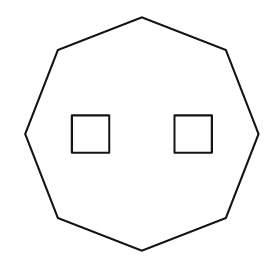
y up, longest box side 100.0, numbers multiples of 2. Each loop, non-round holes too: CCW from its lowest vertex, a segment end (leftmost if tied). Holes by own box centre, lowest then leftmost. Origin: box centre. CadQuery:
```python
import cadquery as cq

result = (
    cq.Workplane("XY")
    .moveTo(0.0, -50.0)
    .lineTo(36.0, -36.0)
    .lineTo(50.0, 0.0)
    .lineTo(36.0, 36.0)
    .lineTo(0.0, 50.0)
    .lineTo(-36.0, 36.0)
    .lineTo(-50.0, 0.0)
    .lineTo(-36.0, -36.0)
    .close()
    .moveTo(-30.0, -8.0)
    .lineTo(-14.0, -8.0)
    .lineTo(-14.0, 8.0)
    .lineTo(-30.0, 8.0)
    .close()
    .moveTo(14.0, -8.0)
    .lineTo(30.0, -8.0)
    .lineTo(30.0, 8.0)
    .lineTo(14.0, 8.0)
    .close()
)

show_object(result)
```